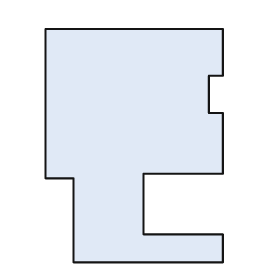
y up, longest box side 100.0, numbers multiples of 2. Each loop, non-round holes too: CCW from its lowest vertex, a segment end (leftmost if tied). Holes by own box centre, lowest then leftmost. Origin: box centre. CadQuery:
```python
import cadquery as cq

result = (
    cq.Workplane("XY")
    .moveTo(-26.0, -50.0)
    .lineTo(38.0, -50.0)
    .lineTo(38.0, -38.0)
    .lineTo(4.0, -38.0)
    .lineTo(4.0, -12.0)
    .lineTo(38.0, -12.0)
    .lineTo(38.0, 14.0)
    .lineTo(32.0, 14.0)
    .lineTo(32.0, 30.0)
    .lineTo(38.0, 30.0)
    .lineTo(38.0, 50.0)
    .lineTo(-38.0, 50.0)
    .lineTo(-38.0, -14.0)
    .lineTo(-26.0, -14.0)
    .close()
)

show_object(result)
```